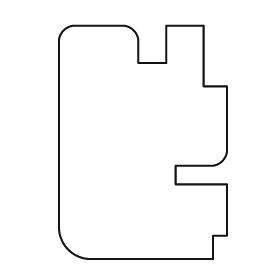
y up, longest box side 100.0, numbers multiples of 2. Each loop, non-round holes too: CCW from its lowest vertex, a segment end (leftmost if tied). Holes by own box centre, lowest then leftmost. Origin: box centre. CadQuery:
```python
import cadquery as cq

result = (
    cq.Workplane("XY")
    .moveTo(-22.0, -50.0)
    .lineTo(30.0, -50.0)
    .lineTo(30.0, -40.0)
    .lineTo(36.0, -40.0)
    .lineTo(36.0, -18.0)
    .lineTo(14.0, -18.0)
    .lineTo(14.0, -10.0)
    .lineTo(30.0, -10.0)
    .threePointArc((34.0, -8.0), (36.0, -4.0))
    .lineTo(36.0, 24.0)
    .lineTo(26.0, 24.0)
    .lineTo(26.0, 50.0)
    .lineTo(10.0, 50.0)
    .lineTo(10.0, 34.0)
    .lineTo(-2.0, 34.0)
    .lineTo(-2.0, 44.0)
    .threePointArc((-4.0, 48.0), (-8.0, 50.0))
    .lineTo(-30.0, 50.0)
    .threePointArc((-34.0, 48.0), (-36.0, 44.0))
    .lineTo(-36.0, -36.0)
    .threePointArc((-32.0, -46.0), (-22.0, -50.0))
    .close()
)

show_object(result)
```